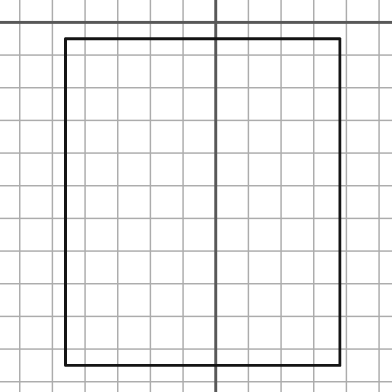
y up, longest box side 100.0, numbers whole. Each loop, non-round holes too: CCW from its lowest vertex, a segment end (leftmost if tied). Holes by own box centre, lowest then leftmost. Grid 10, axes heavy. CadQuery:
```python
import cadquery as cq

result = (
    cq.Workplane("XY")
    .moveTo(-46.0, -105.0)
    .lineTo(38.0, -105.0)
    .lineTo(38.0, -5.0)
    .lineTo(-46.0, -5.0)
    .close()
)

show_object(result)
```